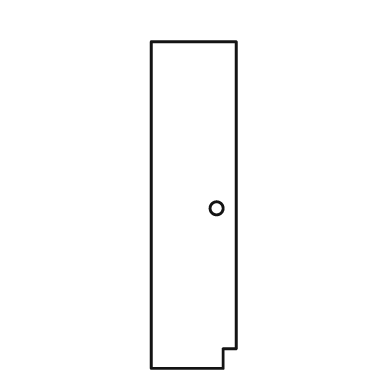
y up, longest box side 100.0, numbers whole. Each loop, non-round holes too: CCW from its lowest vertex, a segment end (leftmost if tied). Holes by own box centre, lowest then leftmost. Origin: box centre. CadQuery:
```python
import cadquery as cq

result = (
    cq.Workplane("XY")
    .moveTo(-13.0, -50.0)
    .lineTo(9.0, -50.0)
    .lineTo(9.0, -44.0)
    .lineTo(13.0, -44.0)
    .lineTo(13.0, 50.0)
    .lineTo(-13.0, 50.0)
    .close()
    .moveTo(7.0, -1.0)
    .circle(2.0)
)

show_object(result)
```